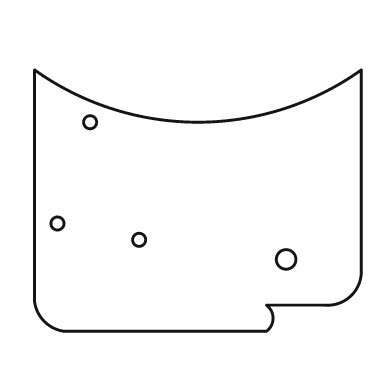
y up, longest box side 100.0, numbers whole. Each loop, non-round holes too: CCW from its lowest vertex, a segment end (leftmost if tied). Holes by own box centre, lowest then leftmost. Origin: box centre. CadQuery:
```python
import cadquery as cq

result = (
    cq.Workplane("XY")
    .moveTo(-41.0, -40.0)
    .lineTo(21.0, -40.0)
    .threePointArc((23.0, -36.0), (21.0, -32.0))
    .lineTo(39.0, -32.0)
    .threePointArc((47.0, -29.0), (50.0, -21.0))
    .lineTo(50.0, 40.0)
    .threePointArc((0.0, 24.0), (-50.0, 40.0))
    .lineTo(-50.0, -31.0)
    .threePointArc((-47.0, -37.0), (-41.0, -40.0))
    .close()
    .moveTo(27.0, -18.0)
    .circle(3.0)
    .moveTo(-18.0, -12.0)
    .circle(2.0)
    .moveTo(-43.0, -7.0)
    .circle(2.0)
    .moveTo(-33.0, 24.0)
    .circle(2.0)
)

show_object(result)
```